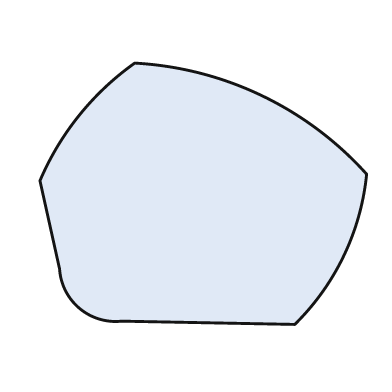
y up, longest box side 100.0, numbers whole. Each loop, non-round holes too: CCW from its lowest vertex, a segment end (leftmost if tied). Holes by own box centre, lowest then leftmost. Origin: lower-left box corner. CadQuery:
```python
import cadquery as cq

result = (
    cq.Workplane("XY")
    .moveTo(78.0, 0.0)
    .threePointArc((93.0, 21.0), (100.0, 46.0))
    .threePointArc((68.0, 70.0), (29.0, 80.0))
    .threePointArc((12.0, 64.0), (0.0, 44.0))
    .lineTo(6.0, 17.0)
    .threePointArc((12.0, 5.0), (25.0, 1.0))
    .close()
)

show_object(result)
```